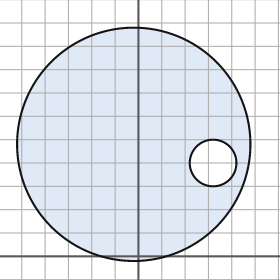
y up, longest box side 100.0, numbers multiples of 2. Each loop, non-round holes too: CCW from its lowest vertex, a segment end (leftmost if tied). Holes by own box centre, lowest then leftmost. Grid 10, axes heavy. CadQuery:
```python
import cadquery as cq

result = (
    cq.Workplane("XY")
    .moveTo(-2.0, 48.0)
    .circle(50.0)
    .moveTo(32.0, 40.0)
    .circle(10.0)
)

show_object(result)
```